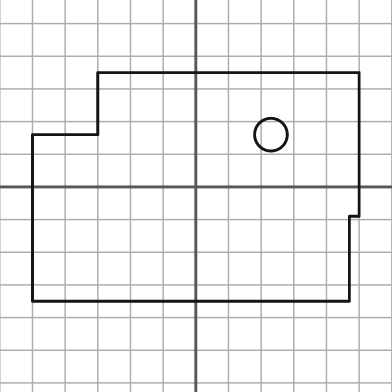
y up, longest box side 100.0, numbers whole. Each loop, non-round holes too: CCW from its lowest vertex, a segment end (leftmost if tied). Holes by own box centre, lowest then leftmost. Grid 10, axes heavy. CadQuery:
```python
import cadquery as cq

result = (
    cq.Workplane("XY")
    .moveTo(-50.0, -35.0)
    .lineTo(47.0, -35.0)
    .lineTo(47.0, -9.0)
    .lineTo(50.0, -9.0)
    .lineTo(50.0, 35.0)
    .lineTo(-30.0, 35.0)
    .lineTo(-30.0, 16.0)
    .lineTo(-50.0, 16.0)
    .close()
    .moveTo(23.0, 16.0)
    .circle(5.0)
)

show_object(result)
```